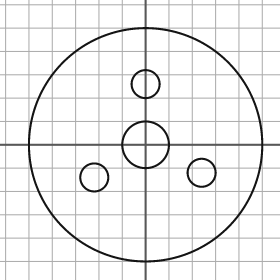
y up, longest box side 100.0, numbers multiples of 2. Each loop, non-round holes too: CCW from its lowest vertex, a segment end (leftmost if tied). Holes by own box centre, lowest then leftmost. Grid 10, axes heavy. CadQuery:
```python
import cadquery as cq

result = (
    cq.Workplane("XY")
    .moveTo(0.0, 0.0)
    .circle(50.0)
    .moveTo(-22.0, -14.0)
    .circle(6.0)
    .moveTo(24.0, -12.0)
    .circle(6.0)
    .moveTo(0.0, 0.0)
    .circle(10.0)
    .moveTo(0.0, 26.0)
    .circle(6.0)
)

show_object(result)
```